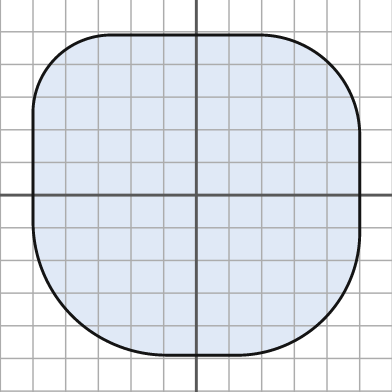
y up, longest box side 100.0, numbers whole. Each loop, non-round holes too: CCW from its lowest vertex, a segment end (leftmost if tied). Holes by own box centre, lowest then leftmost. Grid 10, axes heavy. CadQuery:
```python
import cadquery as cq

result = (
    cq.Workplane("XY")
    .moveTo(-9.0, -49.0)
    .lineTo(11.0, -49.0)
    .threePointArc((39.0, -38.0), (50.0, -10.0))
    .lineTo(50.0, 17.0)
    .threePointArc((41.0, 40.0), (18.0, 49.0))
    .lineTo(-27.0, 49.0)
    .threePointArc((-43.0, 42.0), (-50.0, 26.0))
    .lineTo(-50.0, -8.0)
    .threePointArc((-38.0, -37.0), (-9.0, -49.0))
    .close()
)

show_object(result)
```